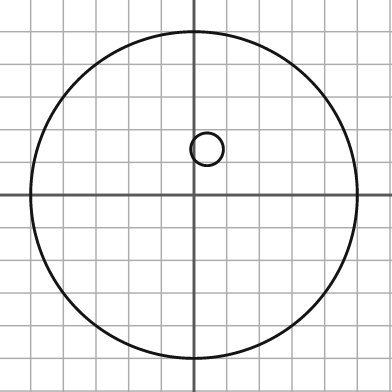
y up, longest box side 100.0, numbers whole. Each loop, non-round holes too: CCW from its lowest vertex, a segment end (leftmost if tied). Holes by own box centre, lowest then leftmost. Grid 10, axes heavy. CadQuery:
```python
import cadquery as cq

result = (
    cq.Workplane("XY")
    .moveTo(0.0, 0.0)
    .circle(50.0)
    .moveTo(4.0, 14.0)
    .circle(5.0)
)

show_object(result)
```